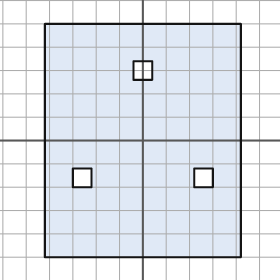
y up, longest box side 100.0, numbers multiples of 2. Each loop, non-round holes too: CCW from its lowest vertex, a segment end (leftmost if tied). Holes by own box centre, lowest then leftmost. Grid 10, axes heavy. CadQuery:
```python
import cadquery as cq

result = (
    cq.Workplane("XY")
    .moveTo(-42.0, -50.0)
    .lineTo(42.0, -50.0)
    .lineTo(42.0, 50.0)
    .lineTo(-42.0, 50.0)
    .close()
    .moveTo(-30.0, -20.0)
    .lineTo(-22.0, -20.0)
    .lineTo(-22.0, -12.0)
    .lineTo(-30.0, -12.0)
    .close()
    .moveTo(22.0, -20.0)
    .lineTo(30.0, -20.0)
    .lineTo(30.0, -12.0)
    .lineTo(22.0, -12.0)
    .close()
    .moveTo(-4.0, 26.0)
    .lineTo(4.0, 26.0)
    .lineTo(4.0, 34.0)
    .lineTo(-4.0, 34.0)
    .close()
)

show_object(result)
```